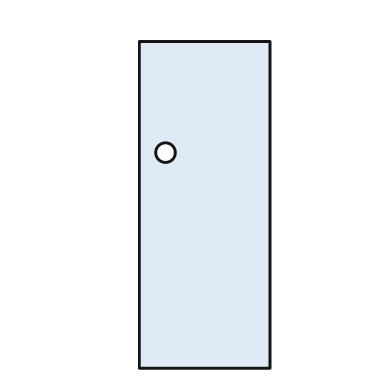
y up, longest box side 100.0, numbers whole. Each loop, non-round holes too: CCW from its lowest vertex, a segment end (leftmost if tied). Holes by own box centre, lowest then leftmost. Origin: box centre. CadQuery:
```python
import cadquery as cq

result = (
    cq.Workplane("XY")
    .moveTo(-20.0, -50.0)
    .lineTo(20.0, -50.0)
    .lineTo(20.0, 50.0)
    .lineTo(-20.0, 50.0)
    .close()
    .moveTo(-12.0, 16.0)
    .circle(3.0)
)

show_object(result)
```